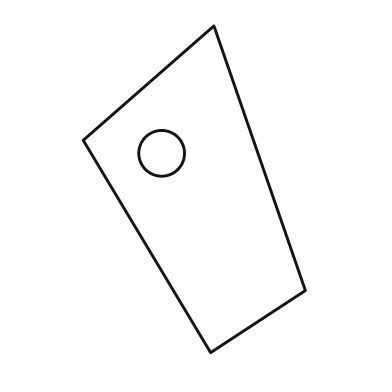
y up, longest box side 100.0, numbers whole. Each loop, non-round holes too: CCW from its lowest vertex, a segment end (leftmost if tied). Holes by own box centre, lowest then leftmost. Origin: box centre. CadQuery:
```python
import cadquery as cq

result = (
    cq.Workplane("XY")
    .moveTo(5.0, -50.0)
    .lineTo(34.0, -31.0)
    .lineTo(6.0, 50.0)
    .lineTo(-34.0, 15.0)
    .close()
    .moveTo(-10.0, 11.0)
    .circle(7.0)
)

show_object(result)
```